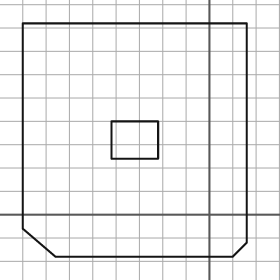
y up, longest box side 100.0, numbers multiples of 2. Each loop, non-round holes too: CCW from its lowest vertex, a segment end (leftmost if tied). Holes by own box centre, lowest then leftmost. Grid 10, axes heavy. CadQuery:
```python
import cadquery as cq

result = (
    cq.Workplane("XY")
    .moveTo(-66.0, -18.0)
    .lineTo(10.0, -18.0)
    .lineTo(16.0, -12.0)
    .lineTo(16.0, 82.0)
    .lineTo(-80.0, 82.0)
    .lineTo(-80.0, -6.0)
    .close()
    .moveTo(-42.0, 24.0)
    .lineTo(-22.0, 24.0)
    .lineTo(-22.0, 40.0)
    .lineTo(-42.0, 40.0)
    .close()
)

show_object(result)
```